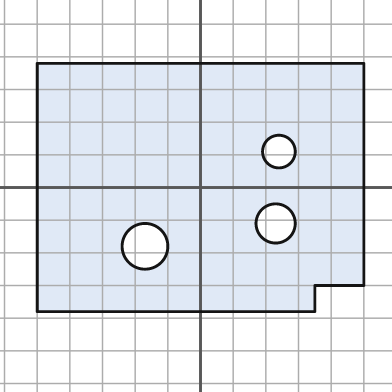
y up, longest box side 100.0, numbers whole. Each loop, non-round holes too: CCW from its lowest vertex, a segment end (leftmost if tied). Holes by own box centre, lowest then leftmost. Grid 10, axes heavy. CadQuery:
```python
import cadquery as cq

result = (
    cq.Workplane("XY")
    .moveTo(-50.0, -38.0)
    .lineTo(35.0, -38.0)
    .lineTo(35.0, -30.0)
    .lineTo(50.0, -30.0)
    .lineTo(50.0, 38.0)
    .lineTo(-50.0, 38.0)
    .close()
    .moveTo(-17.0, -18.0)
    .circle(7.0)
    .moveTo(23.0, -11.0)
    .circle(6.0)
    .moveTo(24.0, 11.0)
    .circle(5.0)
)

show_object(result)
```